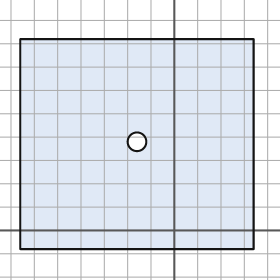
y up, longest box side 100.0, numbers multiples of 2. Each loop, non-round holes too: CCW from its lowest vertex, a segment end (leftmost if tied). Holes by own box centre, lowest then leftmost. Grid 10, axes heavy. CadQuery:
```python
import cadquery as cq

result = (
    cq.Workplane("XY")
    .moveTo(-66.0, -8.0)
    .lineTo(34.0, -8.0)
    .lineTo(34.0, 82.0)
    .lineTo(-66.0, 82.0)
    .close()
    .moveTo(-16.0, 38.0)
    .circle(4.0)
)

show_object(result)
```